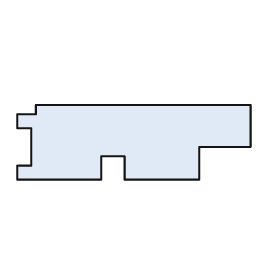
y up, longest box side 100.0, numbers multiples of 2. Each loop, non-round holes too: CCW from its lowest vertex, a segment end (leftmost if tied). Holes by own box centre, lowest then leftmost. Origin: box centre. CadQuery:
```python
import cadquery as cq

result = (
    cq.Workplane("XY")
    .moveTo(-50.0, -16.0)
    .lineTo(-14.0, -16.0)
    .lineTo(-14.0, -6.0)
    .lineTo(-4.0, -6.0)
    .lineTo(-4.0, -16.0)
    .lineTo(28.0, -16.0)
    .lineTo(28.0, -2.0)
    .lineTo(50.0, -2.0)
    .lineTo(50.0, 16.0)
    .lineTo(-42.0, 16.0)
    .lineTo(-42.0, 12.0)
    .lineTo(-50.0, 12.0)
    .lineTo(-50.0, 6.0)
    .lineTo(-44.0, 6.0)
    .lineTo(-44.0, -10.0)
    .lineTo(-50.0, -10.0)
    .close()
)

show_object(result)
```